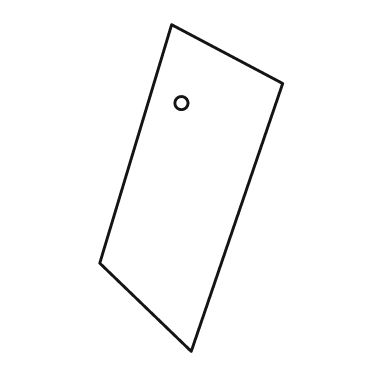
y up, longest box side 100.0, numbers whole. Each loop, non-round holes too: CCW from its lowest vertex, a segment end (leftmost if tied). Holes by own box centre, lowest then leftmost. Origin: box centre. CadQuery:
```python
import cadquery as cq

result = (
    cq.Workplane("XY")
    .moveTo(0.0, -50.0)
    .lineTo(28.0, 32.0)
    .lineTo(-6.0, 50.0)
    .lineTo(-28.0, -23.0)
    .close()
    .moveTo(-3.0, 26.0)
    .circle(2.0)
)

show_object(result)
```